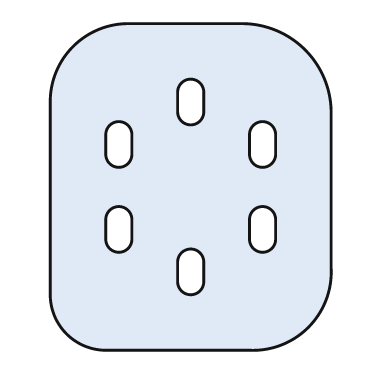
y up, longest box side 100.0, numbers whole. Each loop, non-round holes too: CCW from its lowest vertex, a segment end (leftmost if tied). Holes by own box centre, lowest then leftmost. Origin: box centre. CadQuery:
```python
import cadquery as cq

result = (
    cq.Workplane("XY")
    .moveTo(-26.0, -50.0)
    .lineTo(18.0, -50.0)
    .threePointArc((36.0, -43.0), (43.0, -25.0))
    .lineTo(43.0, 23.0)
    .threePointArc((35.0, 42.0), (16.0, 50.0))
    .lineTo(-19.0, 50.0)
    .threePointArc((-36.0, 43.0), (-43.0, 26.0))
    .lineTo(-43.0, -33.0)
    .threePointArc((-38.0, -45.0), (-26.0, -50.0))
    .close()
    .moveTo(-4.0, -29.0)
    .threePointArc((0.0, -33.0), (4.0, -29.0))
    .lineTo(4.0, -23.0)
    .threePointArc((0.0, -19.0), (-4.0, -23.0))
    .close()
    .moveTo(-26.0, -16.0)
    .threePointArc((-22.0, -20.0), (-18.0, -16.0))
    .lineTo(-18.0, -10.0)
    .threePointArc((-22.0, -6.0), (-26.0, -10.0))
    .close()
    .moveTo(18.0, -16.0)
    .threePointArc((22.0, -20.0), (26.0, -16.0))
    .lineTo(26.0, -10.0)
    .threePointArc((22.0, -6.0), (18.0, -10.0))
    .close()
    .moveTo(-26.0, 10.0)
    .threePointArc((-22.0, 6.0), (-18.0, 10.0))
    .lineTo(-18.0, 16.0)
    .threePointArc((-22.0, 20.0), (-26.0, 16.0))
    .close()
    .moveTo(18.0, 10.0)
    .threePointArc((22.0, 6.0), (26.0, 10.0))
    .lineTo(26.0, 16.0)
    .threePointArc((22.0, 20.0), (18.0, 16.0))
    .close()
    .moveTo(-4.0, 23.0)
    .threePointArc((0.0, 19.0), (4.0, 23.0))
    .lineTo(4.0, 29.0)
    .threePointArc((0.0, 33.0), (-4.0, 29.0))
    .close()
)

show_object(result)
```